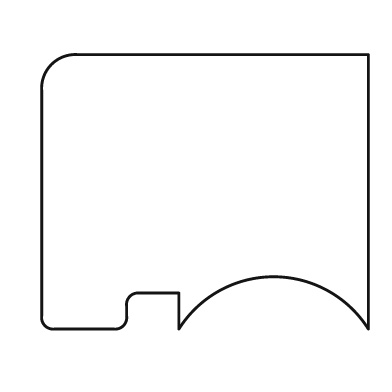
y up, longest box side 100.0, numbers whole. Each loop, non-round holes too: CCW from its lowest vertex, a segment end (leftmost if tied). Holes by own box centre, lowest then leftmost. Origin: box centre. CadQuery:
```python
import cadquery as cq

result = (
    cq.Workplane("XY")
    .moveTo(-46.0, -42.0)
    .lineTo(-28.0, -42.0)
    .threePointArc((-25.0, -41.0), (-24.0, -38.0))
    .lineTo(-24.0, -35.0)
    .threePointArc((-23.0, -32.0), (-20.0, -31.0))
    .lineTo(-8.0, -31.0)
    .lineTo(-8.0, -42.0)
    .threePointArc((21.0, -26.0), (50.0, -42.0))
    .lineTo(50.0, 42.0)
    .lineTo(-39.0, 42.0)
    .threePointArc((-47.0, 39.0), (-50.0, 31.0))
    .lineTo(-50.0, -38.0)
    .threePointArc((-49.0, -41.0), (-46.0, -42.0))
    .close()
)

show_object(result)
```